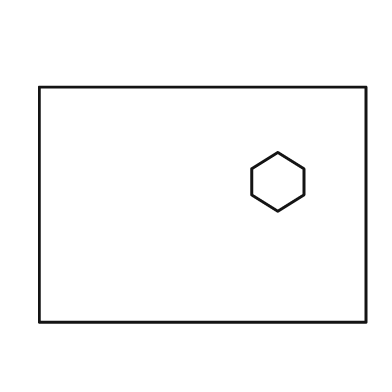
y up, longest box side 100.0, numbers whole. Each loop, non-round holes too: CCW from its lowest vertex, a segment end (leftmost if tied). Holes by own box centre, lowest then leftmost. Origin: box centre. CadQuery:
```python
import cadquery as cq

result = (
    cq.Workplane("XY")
    .moveTo(-50.0, -36.0)
    .lineTo(50.0, -36.0)
    .lineTo(50.0, 36.0)
    .lineTo(-50.0, 36.0)
    .close()
    .moveTo(23.0, -2.0)
    .lineTo(31.0, 3.0)
    .lineTo(31.0, 11.0)
    .lineTo(23.0, 16.0)
    .lineTo(15.0, 11.0)
    .lineTo(15.0, 3.0)
    .close()
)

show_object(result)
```